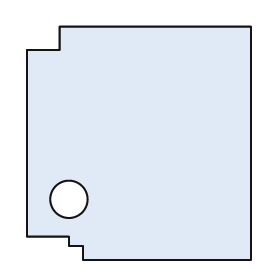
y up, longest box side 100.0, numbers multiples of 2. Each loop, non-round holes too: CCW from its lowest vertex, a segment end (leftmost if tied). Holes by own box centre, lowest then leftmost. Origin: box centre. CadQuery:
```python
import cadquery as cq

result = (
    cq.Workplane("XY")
    .moveTo(-24.0, -50.0)
    .lineTo(48.0, -50.0)
    .lineTo(48.0, 50.0)
    .lineTo(-34.0, 50.0)
    .lineTo(-34.0, 40.0)
    .lineTo(-48.0, 40.0)
    .lineTo(-48.0, -40.0)
    .lineTo(-30.0, -40.0)
    .lineTo(-30.0, -44.0)
    .lineTo(-24.0, -44.0)
    .close()
    .moveTo(-30.0, -24.0)
    .circle(8.0)
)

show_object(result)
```